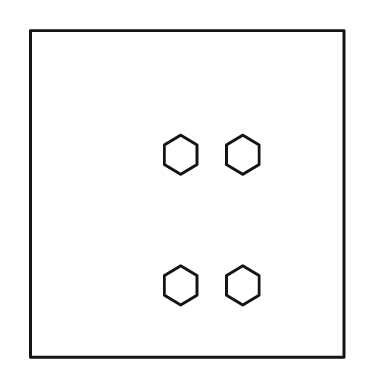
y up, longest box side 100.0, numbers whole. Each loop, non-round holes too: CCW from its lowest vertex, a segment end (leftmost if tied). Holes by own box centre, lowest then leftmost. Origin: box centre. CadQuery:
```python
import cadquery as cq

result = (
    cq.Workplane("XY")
    .moveTo(-48.0, -50.0)
    .lineTo(48.0, -50.0)
    .lineTo(48.0, 50.0)
    .lineTo(-48.0, 50.0)
    .close()
    .moveTo(-2.0, -34.0)
    .lineTo(3.0, -31.0)
    .lineTo(3.0, -25.0)
    .lineTo(-2.0, -22.0)
    .lineTo(-7.0, -25.0)
    .lineTo(-7.0, -31.0)
    .close()
    .moveTo(17.0, -34.0)
    .lineTo(22.0, -31.0)
    .lineTo(22.0, -25.0)
    .lineTo(17.0, -22.0)
    .lineTo(12.0, -25.0)
    .lineTo(12.0, -31.0)
    .close()
    .moveTo(-2.0, 6.0)
    .lineTo(3.0, 9.0)
    .lineTo(3.0, 15.0)
    .lineTo(-2.0, 18.0)
    .lineTo(-7.0, 15.0)
    .lineTo(-7.0, 9.0)
    .close()
    .moveTo(17.0, 6.0)
    .lineTo(22.0, 9.0)
    .lineTo(22.0, 15.0)
    .lineTo(17.0, 18.0)
    .lineTo(12.0, 15.0)
    .lineTo(12.0, 9.0)
    .close()
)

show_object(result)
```